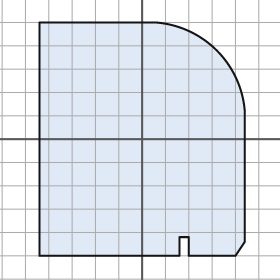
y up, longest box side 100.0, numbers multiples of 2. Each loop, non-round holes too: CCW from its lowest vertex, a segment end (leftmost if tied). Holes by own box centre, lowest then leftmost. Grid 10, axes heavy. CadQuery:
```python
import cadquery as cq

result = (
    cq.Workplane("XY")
    .moveTo(-44.0, -50.0)
    .lineTo(16.0, -50.0)
    .lineTo(16.0, -42.0)
    .lineTo(20.0, -42.0)
    .lineTo(20.0, -50.0)
    .lineTo(40.0, -50.0)
    .lineTo(44.0, -44.0)
    .lineTo(44.0, 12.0)
    .threePointArc((32.0, 38.0), (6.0, 50.0))
    .lineTo(-44.0, 50.0)
    .close()
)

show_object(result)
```